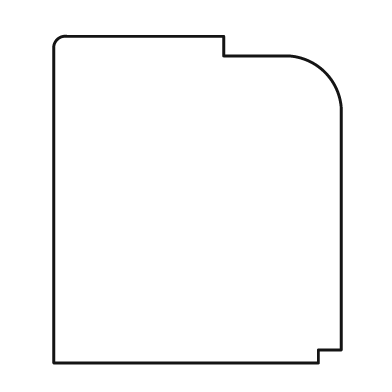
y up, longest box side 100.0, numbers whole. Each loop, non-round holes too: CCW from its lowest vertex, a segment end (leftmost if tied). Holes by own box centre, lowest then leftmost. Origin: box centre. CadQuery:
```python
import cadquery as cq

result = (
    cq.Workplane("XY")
    .moveTo(-44.0, -50.0)
    .lineTo(37.0, -50.0)
    .lineTo(37.0, -46.0)
    .lineTo(44.0, -46.0)
    .lineTo(44.0, 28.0)
    .threePointArc((39.0, 39.0), (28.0, 44.0))
    .lineTo(8.0, 44.0)
    .lineTo(8.0, 50.0)
    .lineTo(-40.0, 50.0)
    .threePointArc((-43.0, 49.0), (-44.0, 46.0))
    .close()
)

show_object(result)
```